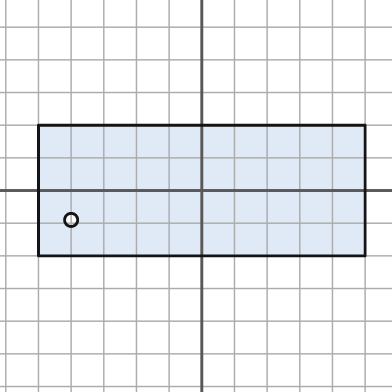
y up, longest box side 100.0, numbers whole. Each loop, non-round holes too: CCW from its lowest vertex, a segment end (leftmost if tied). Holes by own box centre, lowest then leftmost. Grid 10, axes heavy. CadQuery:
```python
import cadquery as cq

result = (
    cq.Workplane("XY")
    .moveTo(-50.0, -20.0)
    .lineTo(50.0, -20.0)
    .lineTo(50.0, 20.0)
    .lineTo(-50.0, 20.0)
    .close()
    .moveTo(-40.0, -9.0)
    .circle(2.0)
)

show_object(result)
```